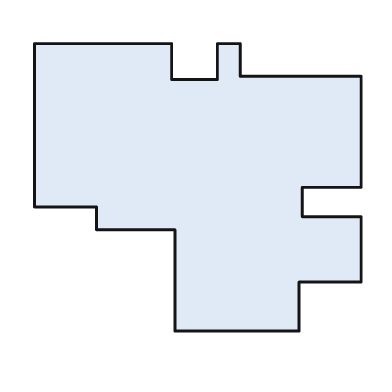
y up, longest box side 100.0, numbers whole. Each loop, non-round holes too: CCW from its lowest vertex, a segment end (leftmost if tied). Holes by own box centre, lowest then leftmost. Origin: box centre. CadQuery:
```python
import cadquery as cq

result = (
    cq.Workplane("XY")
    .moveTo(-7.0, -44.0)
    .lineTo(31.0, -44.0)
    .lineTo(31.0, -29.0)
    .lineTo(50.0, -29.0)
    .lineTo(50.0, -9.0)
    .lineTo(32.0, -9.0)
    .lineTo(32.0, 0.0)
    .lineTo(50.0, 0.0)
    .lineTo(50.0, 34.0)
    .lineTo(13.0, 34.0)
    .lineTo(13.0, 44.0)
    .lineTo(6.0, 44.0)
    .lineTo(6.0, 33.0)
    .lineTo(-8.0, 33.0)
    .lineTo(-8.0, 44.0)
    .lineTo(-50.0, 44.0)
    .lineTo(-50.0, -6.0)
    .lineTo(-31.0, -6.0)
    .lineTo(-31.0, -13.0)
    .lineTo(-7.0, -13.0)
    .close()
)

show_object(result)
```